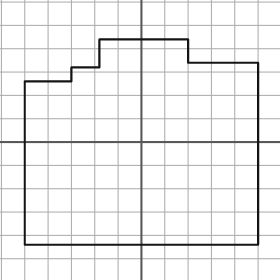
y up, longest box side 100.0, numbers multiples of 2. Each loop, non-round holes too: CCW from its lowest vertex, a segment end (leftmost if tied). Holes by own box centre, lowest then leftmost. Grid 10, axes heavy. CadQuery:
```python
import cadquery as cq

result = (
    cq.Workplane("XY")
    .moveTo(-50.0, -44.0)
    .lineTo(50.0, -44.0)
    .lineTo(50.0, 34.0)
    .lineTo(20.0, 34.0)
    .lineTo(20.0, 44.0)
    .lineTo(-18.0, 44.0)
    .lineTo(-18.0, 32.0)
    .lineTo(-30.0, 32.0)
    .lineTo(-30.0, 26.0)
    .lineTo(-50.0, 26.0)
    .close()
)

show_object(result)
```